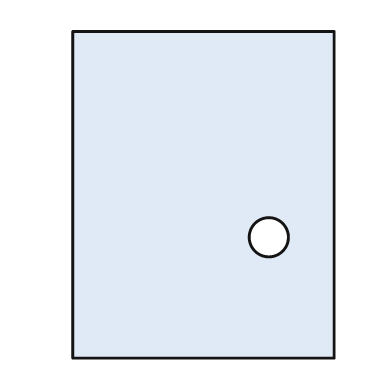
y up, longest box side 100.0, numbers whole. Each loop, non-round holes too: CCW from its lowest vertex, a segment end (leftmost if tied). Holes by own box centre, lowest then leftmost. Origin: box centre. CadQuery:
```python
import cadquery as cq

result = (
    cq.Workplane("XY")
    .moveTo(-40.0, -50.0)
    .lineTo(40.0, -50.0)
    .lineTo(40.0, 50.0)
    .lineTo(-40.0, 50.0)
    .close()
    .moveTo(20.0, -13.0)
    .circle(6.0)
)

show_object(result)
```